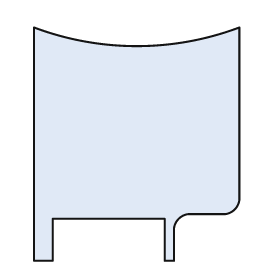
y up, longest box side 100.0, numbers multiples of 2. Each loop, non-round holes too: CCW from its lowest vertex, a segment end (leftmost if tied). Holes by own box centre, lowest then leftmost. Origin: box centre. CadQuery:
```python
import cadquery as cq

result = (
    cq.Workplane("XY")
    .moveTo(-44.0, -50.0)
    .lineTo(-36.0, -50.0)
    .lineTo(-36.0, -32.0)
    .lineTo(12.0, -32.0)
    .lineTo(12.0, -50.0)
    .lineTo(16.0, -50.0)
    .lineTo(16.0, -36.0)
    .threePointArc((18.0, -32.0), (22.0, -30.0))
    .lineTo(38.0, -30.0)
    .threePointArc((42.0, -28.0), (44.0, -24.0))
    .lineTo(44.0, 50.0)
    .threePointArc((0.0, 42.0), (-44.0, 50.0))
    .close()
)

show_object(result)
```